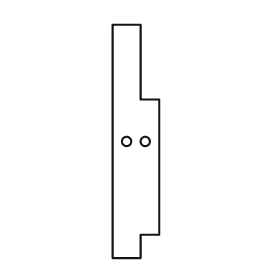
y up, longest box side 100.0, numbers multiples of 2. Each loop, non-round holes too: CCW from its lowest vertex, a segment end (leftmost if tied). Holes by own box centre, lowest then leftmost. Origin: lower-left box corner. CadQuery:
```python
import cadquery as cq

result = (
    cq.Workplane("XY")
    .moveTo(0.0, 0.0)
    .lineTo(12.0, 0.0)
    .lineTo(12.0, 10.0)
    .lineTo(20.0, 10.0)
    .lineTo(20.0, 68.0)
    .lineTo(12.0, 68.0)
    .lineTo(12.0, 100.0)
    .lineTo(0.0, 100.0)
    .close()
    .moveTo(6.0, 50.0)
    .circle(2.0)
    .moveTo(14.0, 50.0)
    .circle(2.0)
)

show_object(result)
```